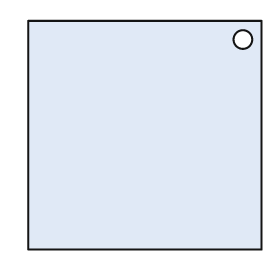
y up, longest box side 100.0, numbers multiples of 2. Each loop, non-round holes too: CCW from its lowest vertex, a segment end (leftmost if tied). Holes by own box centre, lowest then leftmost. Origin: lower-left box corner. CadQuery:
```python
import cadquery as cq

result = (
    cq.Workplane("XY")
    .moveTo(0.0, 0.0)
    .lineTo(100.0, 0.0)
    .lineTo(100.0, 98.0)
    .lineTo(0.0, 98.0)
    .close()
    .moveTo(92.0, 90.0)
    .circle(4.0)
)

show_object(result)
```